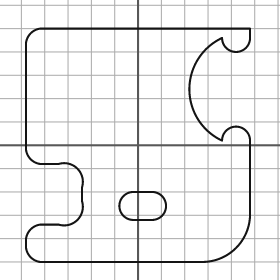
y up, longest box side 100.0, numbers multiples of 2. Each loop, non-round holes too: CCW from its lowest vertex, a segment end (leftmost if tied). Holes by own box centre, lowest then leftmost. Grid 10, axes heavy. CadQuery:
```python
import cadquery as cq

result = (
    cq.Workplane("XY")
    .moveTo(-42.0, -50.0)
    .lineTo(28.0, -50.0)
    .threePointArc((42.0, -44.0), (48.0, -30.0))
    .lineTo(48.0, 2.0)
    .threePointArc((42.0, 8.0), (36.0, 2.0))
    .threePointArc((22.0, 24.0), (36.0, 46.0))
    .threePointArc((42.0, 40.0), (48.0, 46.0))
    .lineTo(48.0, 50.0)
    .lineTo(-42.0, 50.0)
    .threePointArc((-46.0, 48.0), (-48.0, 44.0))
    .lineTo(-48.0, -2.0)
    .threePointArc((-46.0, -6.0), (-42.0, -8.0))
    .lineTo(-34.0, -8.0)
    .threePointArc((-26.0, -10.0), (-24.0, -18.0))
    .lineTo(-24.0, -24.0)
    .threePointArc((-26.0, -32.0), (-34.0, -34.0))
    .lineTo(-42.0, -34.0)
    .threePointArc((-46.0, -36.0), (-48.0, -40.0))
    .lineTo(-48.0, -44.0)
    .threePointArc((-46.0, -48.0), (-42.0, -50.0))
    .close()
    .moveTo(-2.0, -32.0)
    .lineTo(6.0, -32.0)
    .threePointArc((12.0, -26.0), (6.0, -20.0))
    .lineTo(-2.0, -20.0)
    .threePointArc((-8.0, -26.0), (-2.0, -32.0))
    .close()
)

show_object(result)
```